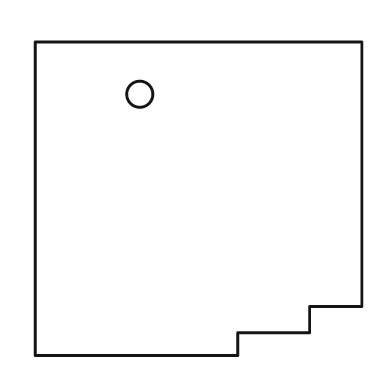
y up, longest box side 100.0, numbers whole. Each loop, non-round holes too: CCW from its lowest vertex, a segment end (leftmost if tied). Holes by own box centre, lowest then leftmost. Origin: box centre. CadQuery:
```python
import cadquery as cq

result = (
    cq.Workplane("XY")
    .moveTo(-50.0, -48.0)
    .lineTo(12.0, -48.0)
    .lineTo(12.0, -41.0)
    .lineTo(34.0, -41.0)
    .lineTo(34.0, -33.0)
    .lineTo(50.0, -33.0)
    .lineTo(50.0, 48.0)
    .lineTo(-50.0, 48.0)
    .close()
    .moveTo(-18.0, 32.0)
    .circle(4.0)
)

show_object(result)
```